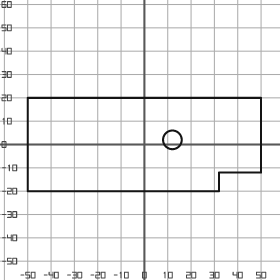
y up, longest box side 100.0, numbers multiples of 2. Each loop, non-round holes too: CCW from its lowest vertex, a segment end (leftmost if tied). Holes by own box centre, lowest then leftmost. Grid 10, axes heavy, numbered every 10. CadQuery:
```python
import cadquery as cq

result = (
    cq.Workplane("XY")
    .moveTo(-50.0, -20.0)
    .lineTo(32.0, -20.0)
    .lineTo(32.0, -12.0)
    .lineTo(50.0, -12.0)
    .lineTo(50.0, 20.0)
    .lineTo(-50.0, 20.0)
    .close()
    .moveTo(12.0, 2.0)
    .circle(4.0)
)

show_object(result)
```